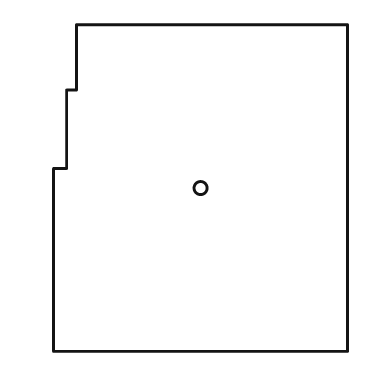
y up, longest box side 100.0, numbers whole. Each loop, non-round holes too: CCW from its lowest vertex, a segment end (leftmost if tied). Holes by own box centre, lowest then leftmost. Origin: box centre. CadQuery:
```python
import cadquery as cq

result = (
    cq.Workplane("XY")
    .moveTo(-45.0, -50.0)
    .lineTo(45.0, -50.0)
    .lineTo(45.0, 50.0)
    .lineTo(-38.0, 50.0)
    .lineTo(-38.0, 30.0)
    .lineTo(-41.0, 30.0)
    .lineTo(-41.0, 6.0)
    .lineTo(-45.0, 6.0)
    .close()
    .moveTo(0.0, 0.0)
    .circle(2.0)
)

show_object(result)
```